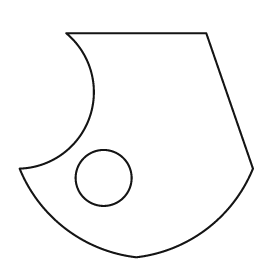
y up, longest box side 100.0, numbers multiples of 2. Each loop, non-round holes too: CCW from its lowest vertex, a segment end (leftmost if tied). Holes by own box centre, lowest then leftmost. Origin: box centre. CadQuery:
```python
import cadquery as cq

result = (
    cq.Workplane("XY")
    .moveTo(0.0, -48.0)
    .threePointArc((30.0, -36.0), (50.0, -10.0))
    .lineTo(30.0, 48.0)
    .lineTo(-30.0, 48.0)
    .threePointArc((-20.0, 12.0), (-50.0, -10.0))
    .threePointArc((-30.0, -36.0), (0.0, -48.0))
    .close()
    .moveTo(-14.0, -14.0)
    .circle(12.0)
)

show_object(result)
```